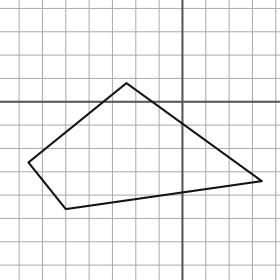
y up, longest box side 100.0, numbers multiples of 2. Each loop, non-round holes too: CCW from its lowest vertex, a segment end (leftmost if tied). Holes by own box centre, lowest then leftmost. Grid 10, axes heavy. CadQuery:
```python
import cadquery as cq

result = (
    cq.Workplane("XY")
    .moveTo(-50.0, -46.0)
    .lineTo(34.0, -34.0)
    .lineTo(-24.0, 8.0)
    .lineTo(-66.0, -26.0)
    .close()
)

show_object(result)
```